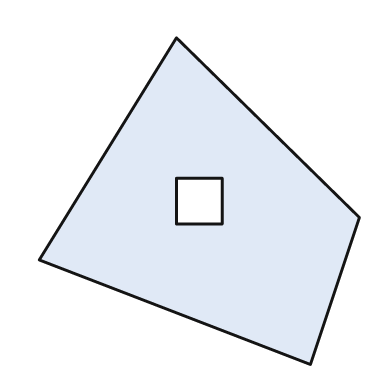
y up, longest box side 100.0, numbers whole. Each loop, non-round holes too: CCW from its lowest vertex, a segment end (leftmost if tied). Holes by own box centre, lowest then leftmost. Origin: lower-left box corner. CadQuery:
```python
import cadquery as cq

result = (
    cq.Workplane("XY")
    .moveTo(83.0, 0.0)
    .lineTo(98.0, 45.0)
    .lineTo(42.0, 100.0)
    .lineTo(0.0, 32.0)
    .close()
    .moveTo(42.0, 43.0)
    .lineTo(56.0, 43.0)
    .lineTo(56.0, 57.0)
    .lineTo(42.0, 57.0)
    .close()
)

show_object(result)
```